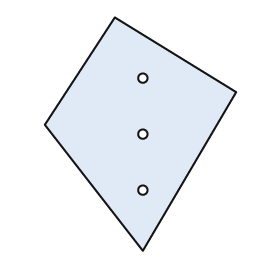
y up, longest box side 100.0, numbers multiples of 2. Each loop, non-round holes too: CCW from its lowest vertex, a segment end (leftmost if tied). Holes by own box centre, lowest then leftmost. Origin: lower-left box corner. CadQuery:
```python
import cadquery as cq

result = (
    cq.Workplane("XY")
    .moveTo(42.0, 0.0)
    .lineTo(82.0, 68.0)
    .lineTo(30.0, 100.0)
    .lineTo(0.0, 54.0)
    .close()
    .moveTo(42.0, 26.0)
    .circle(2.0)
    .moveTo(42.0, 50.0)
    .circle(2.0)
    .moveTo(42.0, 74.0)
    .circle(2.0)
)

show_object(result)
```